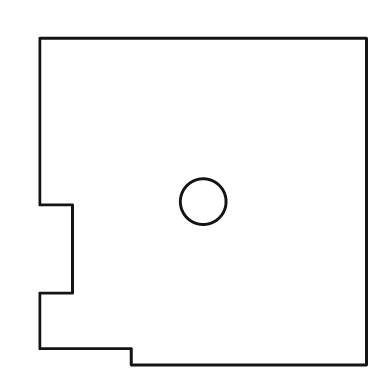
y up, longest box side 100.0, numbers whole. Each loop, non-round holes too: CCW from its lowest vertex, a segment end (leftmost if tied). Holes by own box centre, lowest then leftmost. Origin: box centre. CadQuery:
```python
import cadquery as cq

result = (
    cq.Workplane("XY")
    .moveTo(-22.0, -50.0)
    .lineTo(50.0, -50.0)
    .lineTo(50.0, 50.0)
    .lineTo(-50.0, 50.0)
    .lineTo(-50.0, -1.0)
    .lineTo(-40.0, -1.0)
    .lineTo(-40.0, -28.0)
    .lineTo(-50.0, -28.0)
    .lineTo(-50.0, -45.0)
    .lineTo(-22.0, -45.0)
    .close()
    .moveTo(0.0, 0.0)
    .circle(7.0)
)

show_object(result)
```